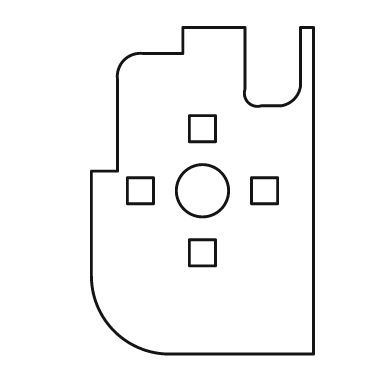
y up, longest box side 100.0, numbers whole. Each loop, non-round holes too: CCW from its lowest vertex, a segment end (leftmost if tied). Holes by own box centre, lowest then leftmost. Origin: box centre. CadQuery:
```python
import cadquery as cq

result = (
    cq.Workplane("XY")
    .moveTo(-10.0, -50.0)
    .lineTo(34.0, -50.0)
    .lineTo(34.0, 50.0)
    .lineTo(30.0, 50.0)
    .lineTo(30.0, 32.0)
    .threePointArc((28.0, 28.0), (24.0, 26.0))
    .lineTo(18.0, 26.0)
    .threePointArc((14.0, 27.0), (13.0, 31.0))
    .lineTo(13.0, 50.0)
    .lineTo(-6.0, 50.0)
    .lineTo(-6.0, 42.0)
    .lineTo(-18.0, 42.0)
    .threePointArc((-24.0, 40.0), (-26.0, 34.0))
    .lineTo(-26.0, 6.0)
    .lineTo(-34.0, 6.0)
    .lineTo(-34.0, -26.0)
    .threePointArc((-27.0, -43.0), (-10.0, -50.0))
    .close()
    .moveTo(-4.0, -23.0)
    .lineTo(4.0, -23.0)
    .lineTo(4.0, -15.0)
    .lineTo(-4.0, -15.0)
    .close()
    .moveTo(-23.0, -4.0)
    .lineTo(-15.0, -4.0)
    .lineTo(-15.0, 4.0)
    .lineTo(-23.0, 4.0)
    .close()
    .moveTo(0.0, 0.0)
    .circle(8.0)
    .moveTo(15.0, -4.0)
    .lineTo(23.0, -4.0)
    .lineTo(23.0, 4.0)
    .lineTo(15.0, 4.0)
    .close()
    .moveTo(-4.0, 15.0)
    .lineTo(4.0, 15.0)
    .lineTo(4.0, 23.0)
    .lineTo(-4.0, 23.0)
    .close()
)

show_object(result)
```